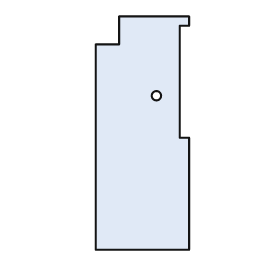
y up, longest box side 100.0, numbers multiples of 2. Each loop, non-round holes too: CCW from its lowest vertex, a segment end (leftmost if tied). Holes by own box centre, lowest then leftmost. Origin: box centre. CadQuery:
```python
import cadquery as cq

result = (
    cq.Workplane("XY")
    .moveTo(-20.0, -50.0)
    .lineTo(20.0, -50.0)
    .lineTo(20.0, -2.0)
    .lineTo(16.0, -2.0)
    .lineTo(16.0, 46.0)
    .lineTo(20.0, 46.0)
    .lineTo(20.0, 50.0)
    .lineTo(-10.0, 50.0)
    .lineTo(-10.0, 38.0)
    .lineTo(-20.0, 38.0)
    .close()
    .moveTo(6.0, 16.0)
    .circle(2.0)
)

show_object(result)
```